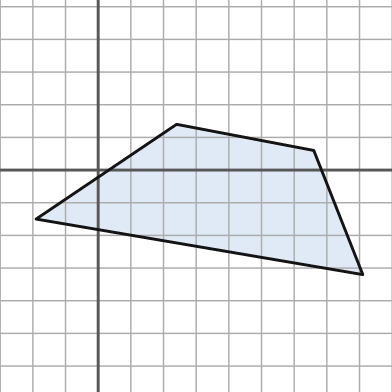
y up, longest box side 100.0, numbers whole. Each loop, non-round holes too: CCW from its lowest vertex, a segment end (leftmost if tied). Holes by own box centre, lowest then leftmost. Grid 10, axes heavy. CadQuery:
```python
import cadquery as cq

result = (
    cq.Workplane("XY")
    .moveTo(81.0, -32.0)
    .lineTo(66.0, 6.0)
    .lineTo(24.0, 14.0)
    .lineTo(-19.0, -15.0)
    .close()
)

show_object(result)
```